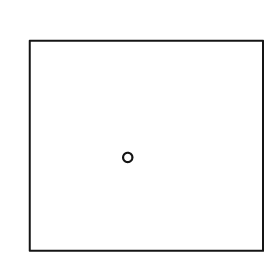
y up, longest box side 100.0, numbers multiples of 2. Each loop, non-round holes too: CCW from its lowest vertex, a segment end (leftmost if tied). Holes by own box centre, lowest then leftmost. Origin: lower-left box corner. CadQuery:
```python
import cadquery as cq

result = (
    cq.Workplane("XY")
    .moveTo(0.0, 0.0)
    .lineTo(100.0, 0.0)
    .lineTo(100.0, 90.0)
    .lineTo(0.0, 90.0)
    .close()
    .moveTo(42.0, 40.0)
    .circle(2.0)
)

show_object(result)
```